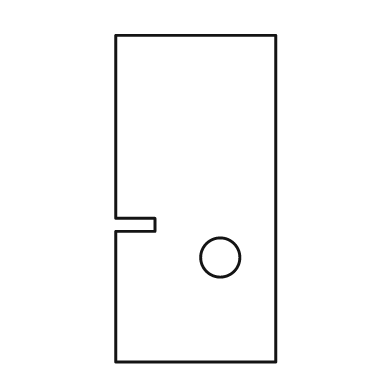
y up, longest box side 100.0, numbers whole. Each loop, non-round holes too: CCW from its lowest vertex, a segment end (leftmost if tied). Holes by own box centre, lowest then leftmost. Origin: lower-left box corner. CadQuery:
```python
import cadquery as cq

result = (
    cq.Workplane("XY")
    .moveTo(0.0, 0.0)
    .lineTo(49.0, 0.0)
    .lineTo(49.0, 100.0)
    .lineTo(0.0, 100.0)
    .lineTo(0.0, 44.0)
    .lineTo(12.0, 44.0)
    .lineTo(12.0, 40.0)
    .lineTo(0.0, 40.0)
    .close()
    .moveTo(32.0, 32.0)
    .circle(6.0)
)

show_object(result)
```